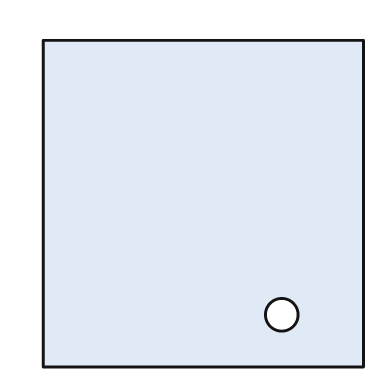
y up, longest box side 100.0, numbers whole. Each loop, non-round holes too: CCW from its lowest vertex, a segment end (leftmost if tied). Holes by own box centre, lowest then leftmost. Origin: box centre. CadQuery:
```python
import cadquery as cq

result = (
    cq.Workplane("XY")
    .moveTo(-49.0, -50.0)
    .lineTo(49.0, -50.0)
    .lineTo(49.0, 50.0)
    .lineTo(-49.0, 50.0)
    .close()
    .moveTo(24.0, -34.0)
    .circle(5.0)
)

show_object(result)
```